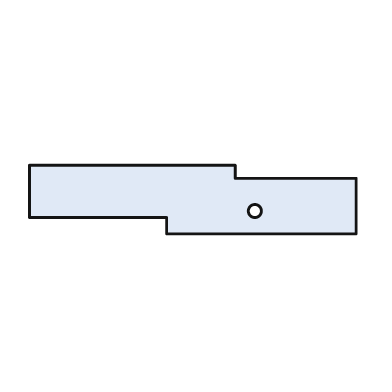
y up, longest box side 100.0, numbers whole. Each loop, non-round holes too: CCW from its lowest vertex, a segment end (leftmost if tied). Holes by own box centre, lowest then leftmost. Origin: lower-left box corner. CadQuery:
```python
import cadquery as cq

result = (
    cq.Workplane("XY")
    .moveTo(42.0, 0.0)
    .lineTo(100.0, 0.0)
    .lineTo(100.0, 17.0)
    .lineTo(63.0, 17.0)
    .lineTo(63.0, 21.0)
    .lineTo(0.0, 21.0)
    .lineTo(0.0, 5.0)
    .lineTo(42.0, 5.0)
    .close()
    .moveTo(69.0, 7.0)
    .circle(2.0)
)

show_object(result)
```